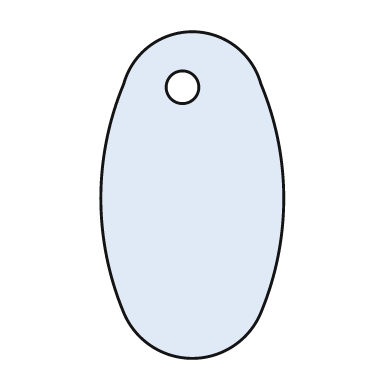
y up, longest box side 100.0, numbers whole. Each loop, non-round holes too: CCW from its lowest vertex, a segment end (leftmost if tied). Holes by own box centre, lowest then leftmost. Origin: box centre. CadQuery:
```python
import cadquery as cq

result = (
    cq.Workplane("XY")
    .moveTo(-21.0, -36.0)
    .threePointArc((0.0, -50.0), (21.0, -36.0))
    .threePointArc((28.0, -1.0), (21.0, 34.0))
    .threePointArc((0.0, 50.0), (-21.0, 34.0))
    .threePointArc((-28.0, -1.0), (-21.0, -36.0))
    .close()
    .moveTo(-3.0, 33.0)
    .circle(5.0)
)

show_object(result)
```